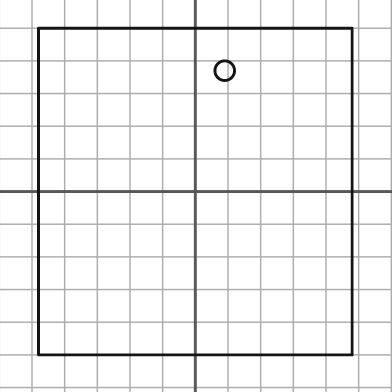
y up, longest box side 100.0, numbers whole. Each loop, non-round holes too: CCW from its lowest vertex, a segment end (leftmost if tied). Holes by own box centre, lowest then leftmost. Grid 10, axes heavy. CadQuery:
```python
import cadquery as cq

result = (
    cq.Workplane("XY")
    .moveTo(-48.0, -50.0)
    .lineTo(48.0, -50.0)
    .lineTo(48.0, 50.0)
    .lineTo(-48.0, 50.0)
    .close()
    .moveTo(9.0, 37.0)
    .circle(3.0)
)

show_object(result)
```